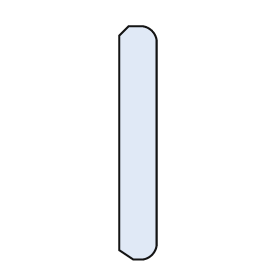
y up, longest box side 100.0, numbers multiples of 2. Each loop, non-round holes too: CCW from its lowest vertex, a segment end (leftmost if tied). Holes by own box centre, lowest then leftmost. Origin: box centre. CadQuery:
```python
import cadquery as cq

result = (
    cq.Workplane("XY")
    .moveTo(-2.0, -50.0)
    .lineTo(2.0, -50.0)
    .threePointArc((6.0, -48.0), (8.0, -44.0))
    .lineTo(8.0, 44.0)
    .threePointArc((6.0, 48.0), (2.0, 50.0))
    .lineTo(-4.0, 50.0)
    .lineTo(-8.0, 46.0)
    .lineTo(-8.0, -46.0)
    .close()
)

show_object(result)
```